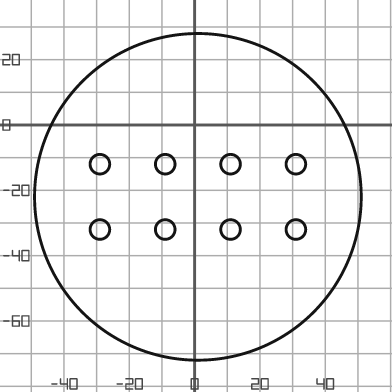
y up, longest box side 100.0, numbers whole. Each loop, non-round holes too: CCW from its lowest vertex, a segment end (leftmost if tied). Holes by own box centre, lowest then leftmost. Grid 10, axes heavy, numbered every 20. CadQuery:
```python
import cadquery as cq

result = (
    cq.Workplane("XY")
    .moveTo(1.0, -22.0)
    .circle(50.0)
    .moveTo(-29.0, -32.0)
    .circle(3.0)
    .moveTo(-9.0, -32.0)
    .circle(3.0)
    .moveTo(11.0, -32.0)
    .circle(3.0)
    .moveTo(31.0, -32.0)
    .circle(3.0)
    .moveTo(-29.0, -12.0)
    .circle(3.0)
    .moveTo(-9.0, -12.0)
    .circle(3.0)
    .moveTo(11.0, -12.0)
    .circle(3.0)
    .moveTo(31.0, -12.0)
    .circle(3.0)
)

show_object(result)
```